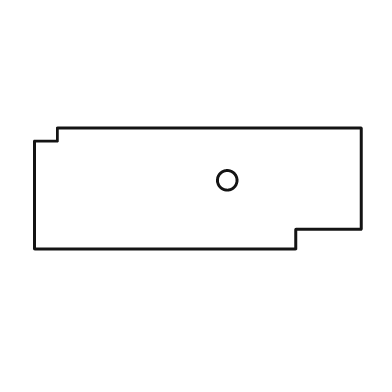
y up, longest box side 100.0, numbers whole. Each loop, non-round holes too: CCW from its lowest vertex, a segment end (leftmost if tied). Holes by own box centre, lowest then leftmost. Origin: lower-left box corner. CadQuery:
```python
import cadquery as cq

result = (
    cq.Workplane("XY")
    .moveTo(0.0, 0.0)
    .lineTo(80.0, 0.0)
    .lineTo(80.0, 6.0)
    .lineTo(100.0, 6.0)
    .lineTo(100.0, 37.0)
    .lineTo(7.0, 37.0)
    .lineTo(7.0, 33.0)
    .lineTo(0.0, 33.0)
    .close()
    .moveTo(59.0, 21.0)
    .circle(3.0)
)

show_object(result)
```